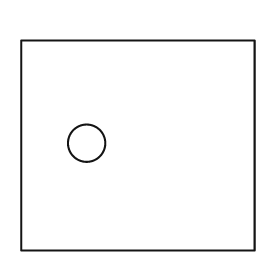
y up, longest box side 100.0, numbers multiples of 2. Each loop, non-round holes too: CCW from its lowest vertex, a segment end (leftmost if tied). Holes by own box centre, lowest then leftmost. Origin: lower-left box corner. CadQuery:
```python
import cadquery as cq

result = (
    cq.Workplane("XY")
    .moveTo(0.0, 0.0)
    .lineTo(100.0, 0.0)
    .lineTo(100.0, 90.0)
    .lineTo(0.0, 90.0)
    .close()
    .moveTo(28.0, 46.0)
    .circle(8.0)
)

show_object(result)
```